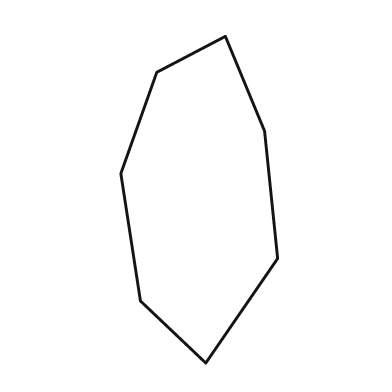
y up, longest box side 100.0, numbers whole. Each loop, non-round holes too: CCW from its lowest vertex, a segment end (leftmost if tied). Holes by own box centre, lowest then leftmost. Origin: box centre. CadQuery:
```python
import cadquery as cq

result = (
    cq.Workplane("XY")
    .moveTo(2.0, -50.0)
    .lineTo(24.0, -18.0)
    .lineTo(20.0, 21.0)
    .lineTo(8.0, 50.0)
    .lineTo(-13.0, 39.0)
    .lineTo(-24.0, 8.0)
    .lineTo(-18.0, -31.0)
    .close()
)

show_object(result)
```